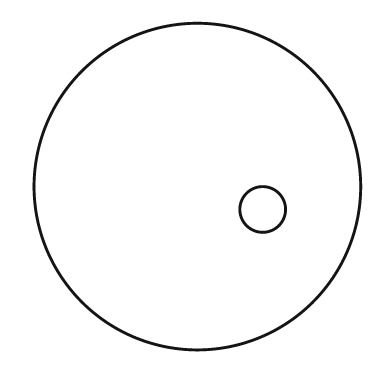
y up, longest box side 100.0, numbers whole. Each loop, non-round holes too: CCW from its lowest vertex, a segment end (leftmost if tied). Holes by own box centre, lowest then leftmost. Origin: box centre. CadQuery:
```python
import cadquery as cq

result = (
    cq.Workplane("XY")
    .moveTo(0.0, 0.0)
    .circle(50.0)
    .moveTo(20.0, -7.0)
    .circle(7.0)
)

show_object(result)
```